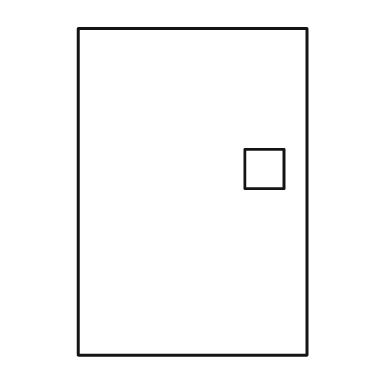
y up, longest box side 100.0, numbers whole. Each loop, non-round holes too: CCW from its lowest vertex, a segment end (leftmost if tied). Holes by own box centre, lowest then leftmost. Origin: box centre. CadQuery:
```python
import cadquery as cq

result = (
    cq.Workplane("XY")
    .moveTo(-35.0, -50.0)
    .lineTo(35.0, -50.0)
    .lineTo(35.0, 50.0)
    .lineTo(-35.0, 50.0)
    .close()
    .moveTo(16.0, 1.0)
    .lineTo(28.0, 1.0)
    .lineTo(28.0, 13.0)
    .lineTo(16.0, 13.0)
    .close()
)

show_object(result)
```